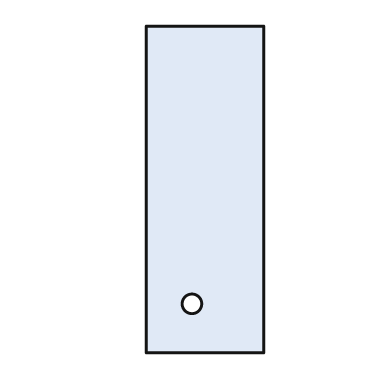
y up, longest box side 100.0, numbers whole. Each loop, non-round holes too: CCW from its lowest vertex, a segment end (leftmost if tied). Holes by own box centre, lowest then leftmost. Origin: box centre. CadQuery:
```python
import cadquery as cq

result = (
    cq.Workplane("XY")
    .moveTo(-18.0, -50.0)
    .lineTo(18.0, -50.0)
    .lineTo(18.0, 50.0)
    .lineTo(-18.0, 50.0)
    .close()
    .moveTo(-4.0, -35.0)
    .circle(3.0)
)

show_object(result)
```